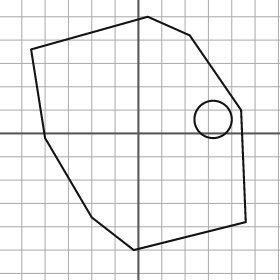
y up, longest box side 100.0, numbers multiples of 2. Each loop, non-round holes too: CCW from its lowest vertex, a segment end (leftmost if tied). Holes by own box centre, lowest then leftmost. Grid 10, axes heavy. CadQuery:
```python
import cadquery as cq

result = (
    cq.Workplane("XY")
    .moveTo(-2.0, -50.0)
    .lineTo(46.0, -38.0)
    .lineTo(44.0, 10.0)
    .lineTo(22.0, 42.0)
    .lineTo(4.0, 50.0)
    .lineTo(-46.0, 36.0)
    .lineTo(-40.0, -2.0)
    .lineTo(-20.0, -36.0)
    .close()
    .moveTo(32.0, 6.0)
    .circle(8.0)
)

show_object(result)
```